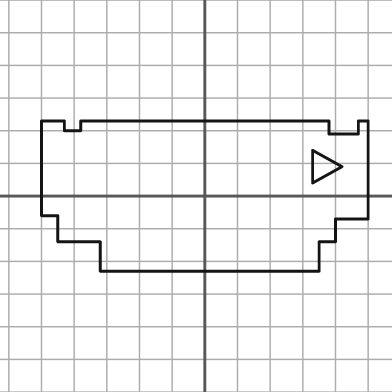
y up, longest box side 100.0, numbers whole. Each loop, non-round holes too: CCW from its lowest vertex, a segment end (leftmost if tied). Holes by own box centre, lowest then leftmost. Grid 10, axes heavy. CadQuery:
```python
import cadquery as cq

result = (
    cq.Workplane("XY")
    .moveTo(-32.0, -23.0)
    .lineTo(35.0, -23.0)
    .lineTo(35.0, -14.0)
    .lineTo(40.0, -14.0)
    .lineTo(40.0, -7.0)
    .lineTo(50.0, -7.0)
    .lineTo(50.0, 23.0)
    .lineTo(47.0, 23.0)
    .lineTo(47.0, 19.0)
    .lineTo(38.0, 19.0)
    .lineTo(38.0, 23.0)
    .lineTo(-38.0, 23.0)
    .lineTo(-38.0, 20.0)
    .lineTo(-43.0, 20.0)
    .lineTo(-43.0, 23.0)
    .lineTo(-50.0, 23.0)
    .lineTo(-50.0, -6.0)
    .lineTo(-45.0, -6.0)
    .lineTo(-45.0, -14.0)
    .lineTo(-32.0, -14.0)
    .close()
    .moveTo(33.0, 4.0)
    .lineTo(42.0, 9.0)
    .lineTo(33.0, 14.0)
    .close()
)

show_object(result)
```